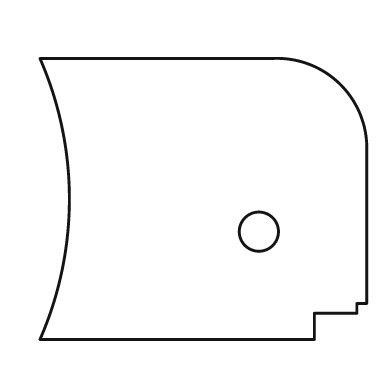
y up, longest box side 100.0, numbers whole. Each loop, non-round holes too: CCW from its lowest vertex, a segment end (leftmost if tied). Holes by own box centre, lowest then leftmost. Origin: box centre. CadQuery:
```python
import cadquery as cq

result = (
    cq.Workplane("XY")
    .moveTo(-50.0, -43.0)
    .lineTo(34.0, -43.0)
    .lineTo(34.0, -35.0)
    .lineTo(47.0, -35.0)
    .lineTo(47.0, -32.0)
    .lineTo(50.0, -32.0)
    .lineTo(50.0, 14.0)
    .threePointArc((42.0, 35.0), (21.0, 43.0))
    .lineTo(-50.0, 43.0)
    .threePointArc((-41.0, 0.0), (-50.0, -43.0))
    .close()
    .moveTo(17.0, -10.0)
    .circle(6.0)
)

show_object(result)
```